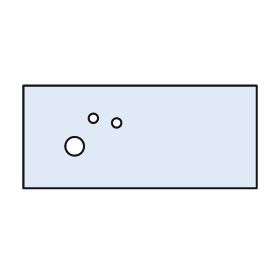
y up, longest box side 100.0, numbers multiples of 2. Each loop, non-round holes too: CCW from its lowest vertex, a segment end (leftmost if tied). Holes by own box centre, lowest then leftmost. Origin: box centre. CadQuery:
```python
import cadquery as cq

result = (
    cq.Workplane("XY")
    .moveTo(-50.0, -22.0)
    .lineTo(50.0, -22.0)
    .lineTo(50.0, 22.0)
    .lineTo(-50.0, 22.0)
    .close()
    .moveTo(-28.0, -4.0)
    .circle(4.0)
    .moveTo(-10.0, 6.0)
    .circle(2.0)
    .moveTo(-20.0, 8.0)
    .circle(2.0)
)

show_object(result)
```